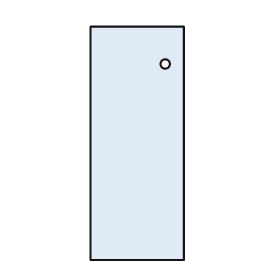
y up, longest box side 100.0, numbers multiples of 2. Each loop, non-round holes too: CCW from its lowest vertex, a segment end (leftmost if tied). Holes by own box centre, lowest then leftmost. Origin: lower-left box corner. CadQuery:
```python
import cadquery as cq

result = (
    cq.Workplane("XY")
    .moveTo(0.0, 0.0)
    .lineTo(40.0, 0.0)
    .lineTo(40.0, 100.0)
    .lineTo(0.0, 100.0)
    .close()
    .moveTo(32.0, 84.0)
    .circle(2.0)
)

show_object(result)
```